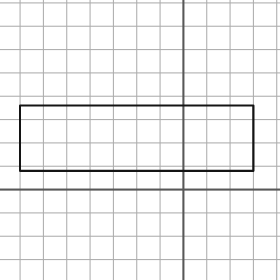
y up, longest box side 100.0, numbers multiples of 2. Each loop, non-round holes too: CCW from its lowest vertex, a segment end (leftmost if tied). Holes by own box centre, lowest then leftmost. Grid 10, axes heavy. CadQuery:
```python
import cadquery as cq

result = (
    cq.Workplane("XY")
    .moveTo(-70.0, 8.0)
    .lineTo(30.0, 8.0)
    .lineTo(30.0, 36.0)
    .lineTo(-70.0, 36.0)
    .close()
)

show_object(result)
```